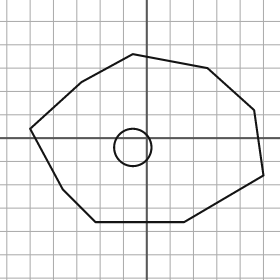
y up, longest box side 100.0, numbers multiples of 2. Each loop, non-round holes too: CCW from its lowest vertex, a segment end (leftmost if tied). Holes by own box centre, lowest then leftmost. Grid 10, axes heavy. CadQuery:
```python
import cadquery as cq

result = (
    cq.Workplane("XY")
    .moveTo(-22.0, -36.0)
    .lineTo(16.0, -36.0)
    .lineTo(50.0, -16.0)
    .lineTo(46.0, 12.0)
    .lineTo(26.0, 30.0)
    .lineTo(-6.0, 36.0)
    .lineTo(-28.0, 24.0)
    .lineTo(-50.0, 4.0)
    .lineTo(-36.0, -22.0)
    .close()
    .moveTo(-6.0, -4.0)
    .circle(8.0)
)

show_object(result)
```